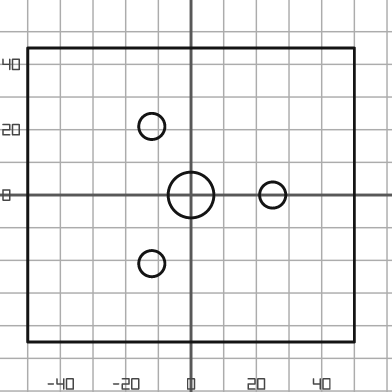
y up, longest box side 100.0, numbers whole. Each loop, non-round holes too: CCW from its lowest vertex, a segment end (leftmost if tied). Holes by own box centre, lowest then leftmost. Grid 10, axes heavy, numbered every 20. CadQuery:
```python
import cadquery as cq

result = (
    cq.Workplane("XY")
    .moveTo(-50.0, -45.0)
    .lineTo(50.0, -45.0)
    .lineTo(50.0, 45.0)
    .lineTo(-50.0, 45.0)
    .close()
    .moveTo(-12.0, -21.0)
    .circle(4.0)
    .moveTo(0.0, 0.0)
    .circle(7.0)
    .moveTo(25.0, 0.0)
    .circle(4.0)
    .moveTo(-12.0, 21.0)
    .circle(4.0)
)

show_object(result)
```